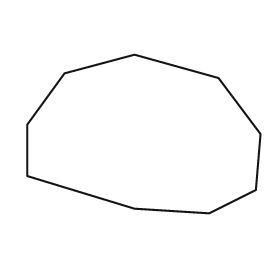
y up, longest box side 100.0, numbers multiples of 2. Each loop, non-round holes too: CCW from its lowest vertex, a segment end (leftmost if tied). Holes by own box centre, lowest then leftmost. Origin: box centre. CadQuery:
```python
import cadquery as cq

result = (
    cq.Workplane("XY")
    .moveTo(28.0, -34.0)
    .lineTo(48.0, -24.0)
    .lineTo(50.0, 0.0)
    .lineTo(32.0, 24.0)
    .lineTo(-4.0, 34.0)
    .lineTo(-34.0, 26.0)
    .lineTo(-50.0, 4.0)
    .lineTo(-50.0, -18.0)
    .lineTo(-4.0, -32.0)
    .close()
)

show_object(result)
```